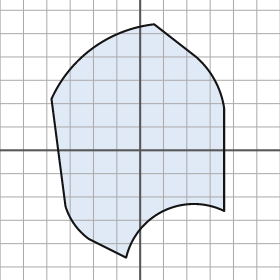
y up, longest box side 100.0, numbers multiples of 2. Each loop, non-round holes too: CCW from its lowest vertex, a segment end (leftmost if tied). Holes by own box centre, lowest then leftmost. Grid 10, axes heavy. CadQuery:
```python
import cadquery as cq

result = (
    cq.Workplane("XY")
    .moveTo(-6.0, -46.0)
    .threePointArc((10.0, -26.0), (36.0, -26.0))
    .lineTo(36.0, 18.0)
    .threePointArc((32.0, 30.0), (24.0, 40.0))
    .lineTo(6.0, 54.0)
    .threePointArc((-20.0, 44.0), (-38.0, 22.0))
    .lineTo(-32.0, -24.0)
    .threePointArc((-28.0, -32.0), (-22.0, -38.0))
    .close()
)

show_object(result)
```